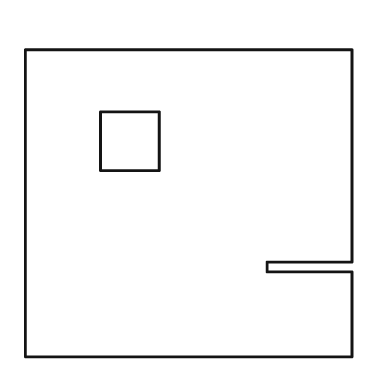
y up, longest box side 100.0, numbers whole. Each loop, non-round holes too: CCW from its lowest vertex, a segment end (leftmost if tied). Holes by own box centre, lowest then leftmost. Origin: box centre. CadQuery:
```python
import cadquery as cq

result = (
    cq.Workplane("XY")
    .moveTo(-50.0, -47.0)
    .lineTo(50.0, -47.0)
    .lineTo(50.0, -21.0)
    .lineTo(24.0, -21.0)
    .lineTo(24.0, -18.0)
    .lineTo(50.0, -18.0)
    .lineTo(50.0, 47.0)
    .lineTo(-50.0, 47.0)
    .close()
    .moveTo(-27.0, 10.0)
    .lineTo(-9.0, 10.0)
    .lineTo(-9.0, 28.0)
    .lineTo(-27.0, 28.0)
    .close()
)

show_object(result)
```